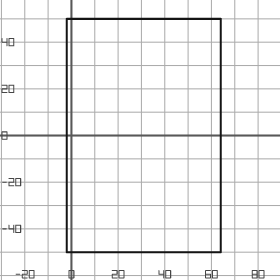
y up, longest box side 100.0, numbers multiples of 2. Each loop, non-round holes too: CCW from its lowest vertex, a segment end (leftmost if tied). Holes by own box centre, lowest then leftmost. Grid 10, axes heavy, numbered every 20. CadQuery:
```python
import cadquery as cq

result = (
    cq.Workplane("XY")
    .moveTo(-2.0, -50.0)
    .lineTo(64.0, -50.0)
    .lineTo(64.0, 50.0)
    .lineTo(-2.0, 50.0)
    .close()
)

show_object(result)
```